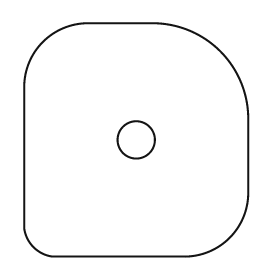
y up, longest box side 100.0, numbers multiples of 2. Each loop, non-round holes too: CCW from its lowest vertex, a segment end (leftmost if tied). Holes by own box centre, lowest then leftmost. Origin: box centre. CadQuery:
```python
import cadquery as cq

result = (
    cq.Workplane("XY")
    .moveTo(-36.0, -50.0)
    .lineTo(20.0, -50.0)
    .threePointArc((40.0, -42.0), (48.0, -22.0))
    .lineTo(48.0, 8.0)
    .threePointArc((36.0, 38.0), (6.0, 50.0))
    .lineTo(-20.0, 50.0)
    .threePointArc((-40.0, 42.0), (-48.0, 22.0))
    .lineTo(-48.0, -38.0)
    .threePointArc((-44.0, -46.0), (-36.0, -50.0))
    .close()
    .moveTo(0.0, 0.0)
    .circle(8.0)
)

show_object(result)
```